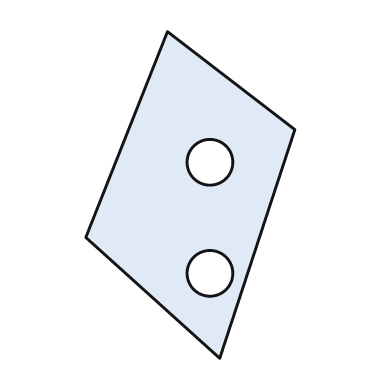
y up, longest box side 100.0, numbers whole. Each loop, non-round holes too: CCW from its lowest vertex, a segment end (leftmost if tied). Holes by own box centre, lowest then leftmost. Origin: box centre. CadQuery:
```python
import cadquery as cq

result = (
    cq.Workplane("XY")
    .moveTo(9.0, -50.0)
    .lineTo(32.0, 20.0)
    .lineTo(-7.0, 50.0)
    .lineTo(-32.0, -13.0)
    .close()
    .moveTo(6.0, -24.0)
    .circle(7.0)
    .moveTo(6.0, 10.0)
    .circle(7.0)
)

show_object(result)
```